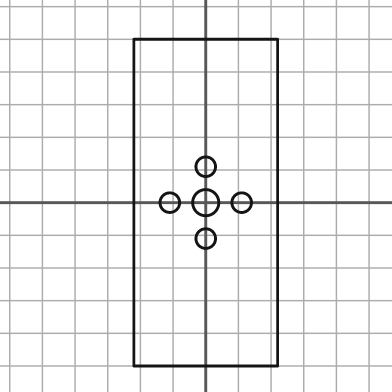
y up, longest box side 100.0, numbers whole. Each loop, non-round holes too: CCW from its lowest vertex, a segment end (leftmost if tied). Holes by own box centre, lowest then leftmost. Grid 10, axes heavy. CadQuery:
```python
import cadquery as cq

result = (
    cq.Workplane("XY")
    .moveTo(-22.0, -50.0)
    .lineTo(22.0, -50.0)
    .lineTo(22.0, 50.0)
    .lineTo(-22.0, 50.0)
    .close()
    .moveTo(0.0, -11.0)
    .circle(3.0)
    .moveTo(-11.0, 0.0)
    .circle(3.0)
    .moveTo(0.0, 0.0)
    .circle(4.0)
    .moveTo(11.0, 0.0)
    .circle(3.0)
    .moveTo(0.0, 11.0)
    .circle(3.0)
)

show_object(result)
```